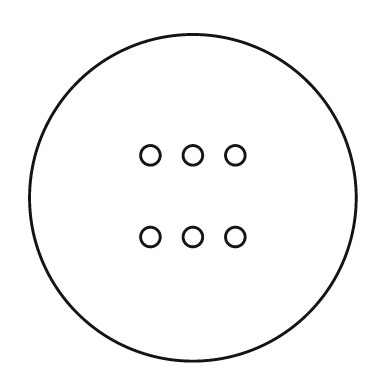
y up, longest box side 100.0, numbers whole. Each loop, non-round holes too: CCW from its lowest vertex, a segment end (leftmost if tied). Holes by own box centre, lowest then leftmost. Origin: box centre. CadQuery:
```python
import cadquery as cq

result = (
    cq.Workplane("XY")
    .moveTo(0.0, 0.0)
    .circle(50.0)
    .moveTo(-13.0, -12.0)
    .circle(3.0)
    .moveTo(0.0, -12.0)
    .circle(3.0)
    .moveTo(13.0, -12.0)
    .circle(3.0)
    .moveTo(-13.0, 13.0)
    .circle(3.0)
    .moveTo(0.0, 13.0)
    .circle(3.0)
    .moveTo(13.0, 13.0)
    .circle(3.0)
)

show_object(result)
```